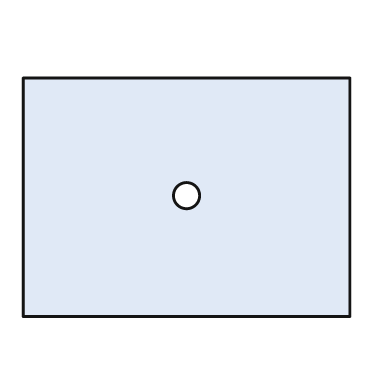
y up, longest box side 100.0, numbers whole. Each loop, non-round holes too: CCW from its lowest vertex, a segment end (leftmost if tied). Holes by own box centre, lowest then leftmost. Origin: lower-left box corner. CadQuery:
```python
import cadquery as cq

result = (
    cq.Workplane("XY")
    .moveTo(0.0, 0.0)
    .lineTo(100.0, 0.0)
    .lineTo(100.0, 73.0)
    .lineTo(0.0, 73.0)
    .close()
    .moveTo(50.0, 37.0)
    .circle(4.0)
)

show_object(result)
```